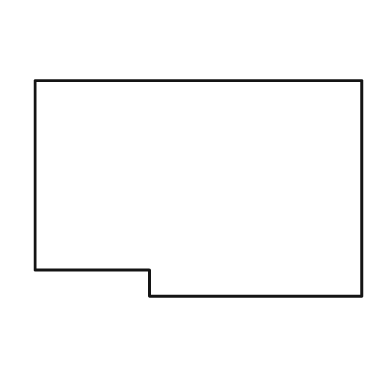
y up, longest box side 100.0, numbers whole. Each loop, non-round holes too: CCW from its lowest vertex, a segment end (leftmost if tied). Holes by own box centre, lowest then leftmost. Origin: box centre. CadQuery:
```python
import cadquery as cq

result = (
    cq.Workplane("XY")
    .moveTo(-15.0, -33.0)
    .lineTo(50.0, -33.0)
    .lineTo(50.0, 33.0)
    .lineTo(-50.0, 33.0)
    .lineTo(-50.0, -25.0)
    .lineTo(-15.0, -25.0)
    .close()
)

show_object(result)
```